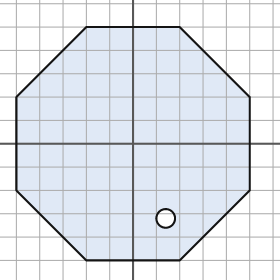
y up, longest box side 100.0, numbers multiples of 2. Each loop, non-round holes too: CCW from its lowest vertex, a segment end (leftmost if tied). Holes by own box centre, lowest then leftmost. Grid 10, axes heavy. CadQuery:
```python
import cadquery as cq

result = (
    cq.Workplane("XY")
    .moveTo(-20.0, -50.0)
    .lineTo(20.0, -50.0)
    .lineTo(50.0, -20.0)
    .lineTo(50.0, 20.0)
    .lineTo(20.0, 50.0)
    .lineTo(-20.0, 50.0)
    .lineTo(-50.0, 20.0)
    .lineTo(-50.0, -20.0)
    .close()
    .moveTo(14.0, -32.0)
    .circle(4.0)
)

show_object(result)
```